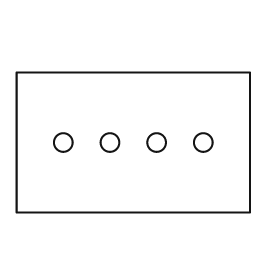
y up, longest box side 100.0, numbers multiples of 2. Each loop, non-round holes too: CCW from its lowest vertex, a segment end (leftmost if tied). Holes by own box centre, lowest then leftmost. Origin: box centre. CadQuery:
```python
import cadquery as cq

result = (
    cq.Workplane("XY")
    .moveTo(-50.0, -30.0)
    .lineTo(50.0, -30.0)
    .lineTo(50.0, 30.0)
    .lineTo(-50.0, 30.0)
    .close()
    .moveTo(-30.0, 0.0)
    .circle(4.0)
    .moveTo(-10.0, 0.0)
    .circle(4.0)
    .moveTo(10.0, 0.0)
    .circle(4.0)
    .moveTo(30.0, 0.0)
    .circle(4.0)
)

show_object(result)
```